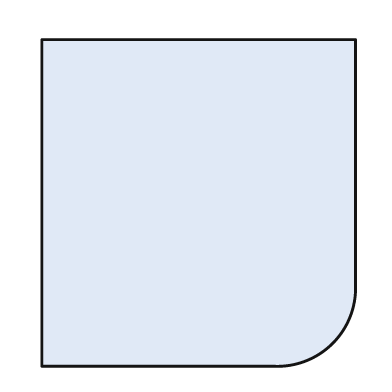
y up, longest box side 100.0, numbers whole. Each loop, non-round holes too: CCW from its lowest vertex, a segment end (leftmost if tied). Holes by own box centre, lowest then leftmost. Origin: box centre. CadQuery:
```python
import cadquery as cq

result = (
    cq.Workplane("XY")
    .moveTo(-48.0, -50.0)
    .lineTo(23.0, -50.0)
    .threePointArc((41.0, -43.0), (48.0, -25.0))
    .lineTo(48.0, 50.0)
    .lineTo(-48.0, 50.0)
    .close()
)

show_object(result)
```